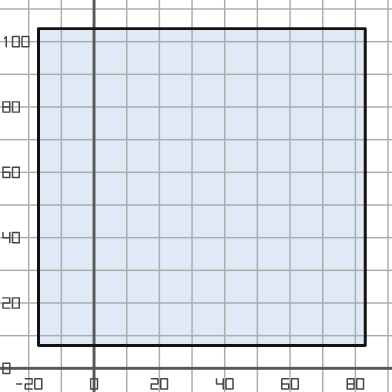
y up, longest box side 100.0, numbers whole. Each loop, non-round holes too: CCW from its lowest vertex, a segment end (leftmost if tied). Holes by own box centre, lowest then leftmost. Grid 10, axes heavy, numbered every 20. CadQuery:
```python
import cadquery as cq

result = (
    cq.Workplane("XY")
    .moveTo(-17.0, 7.0)
    .lineTo(83.0, 7.0)
    .lineTo(83.0, 104.0)
    .lineTo(-17.0, 104.0)
    .close()
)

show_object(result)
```